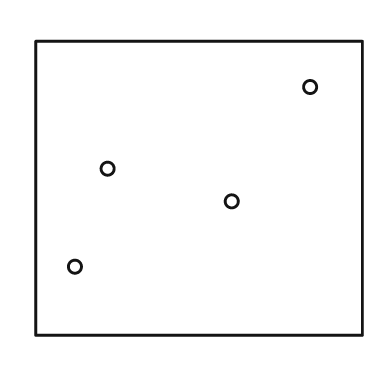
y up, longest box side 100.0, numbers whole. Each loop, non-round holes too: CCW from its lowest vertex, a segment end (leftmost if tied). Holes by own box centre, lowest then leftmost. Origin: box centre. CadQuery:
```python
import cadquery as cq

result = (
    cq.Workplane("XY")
    .moveTo(-50.0, -45.0)
    .lineTo(50.0, -45.0)
    .lineTo(50.0, 45.0)
    .lineTo(-50.0, 45.0)
    .close()
    .moveTo(-38.0, -24.0)
    .circle(2.0)
    .moveTo(10.0, -4.0)
    .circle(2.0)
    .moveTo(-28.0, 6.0)
    .circle(2.0)
    .moveTo(34.0, 31.0)
    .circle(2.0)
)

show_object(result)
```